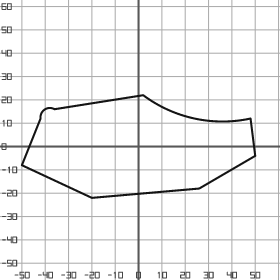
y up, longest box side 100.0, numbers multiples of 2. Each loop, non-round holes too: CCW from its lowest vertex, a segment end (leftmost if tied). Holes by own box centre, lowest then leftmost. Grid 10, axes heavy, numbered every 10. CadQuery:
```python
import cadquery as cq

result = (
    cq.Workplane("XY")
    .moveTo(-20.0, -22.0)
    .lineTo(26.0, -18.0)
    .lineTo(50.0, -4.0)
    .lineTo(48.0, 12.0)
    .threePointArc((24.0, 12.0), (2.0, 22.0))
    .lineTo(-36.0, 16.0)
    .threePointArc((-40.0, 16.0), (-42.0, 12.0))
    .lineTo(-50.0, -8.0)
    .close()
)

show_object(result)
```